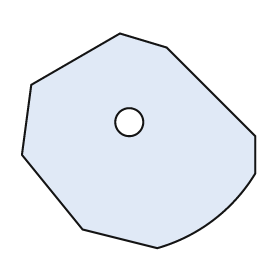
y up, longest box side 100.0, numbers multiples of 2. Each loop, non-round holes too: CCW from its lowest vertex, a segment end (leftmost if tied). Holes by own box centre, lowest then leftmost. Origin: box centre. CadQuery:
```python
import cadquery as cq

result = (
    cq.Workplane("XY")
    .moveTo(8.0, -46.0)
    .threePointArc((32.0, -34.0), (50.0, -14.0))
    .lineTo(50.0, 2.0)
    .lineTo(12.0, 40.0)
    .lineTo(-8.0, 46.0)
    .lineTo(-46.0, 24.0)
    .lineTo(-50.0, -6.0)
    .lineTo(-24.0, -38.0)
    .close()
    .moveTo(-4.0, 8.0)
    .circle(6.0)
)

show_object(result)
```